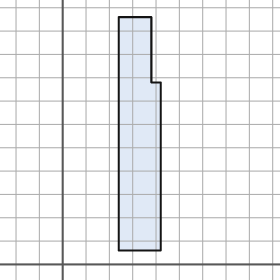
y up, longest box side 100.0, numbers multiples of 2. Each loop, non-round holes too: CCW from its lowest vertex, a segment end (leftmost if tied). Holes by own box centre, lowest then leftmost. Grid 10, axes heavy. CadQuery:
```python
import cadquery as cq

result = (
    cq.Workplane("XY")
    .moveTo(24.0, 6.0)
    .lineTo(42.0, 6.0)
    .lineTo(42.0, 78.0)
    .lineTo(38.0, 78.0)
    .lineTo(38.0, 106.0)
    .lineTo(24.0, 106.0)
    .close()
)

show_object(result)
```